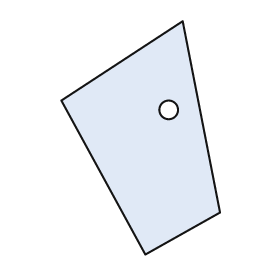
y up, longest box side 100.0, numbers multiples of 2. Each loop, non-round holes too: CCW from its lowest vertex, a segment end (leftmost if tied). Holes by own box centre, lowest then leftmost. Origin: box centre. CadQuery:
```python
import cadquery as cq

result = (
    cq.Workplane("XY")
    .moveTo(2.0, -50.0)
    .lineTo(34.0, -32.0)
    .lineTo(18.0, 50.0)
    .lineTo(-34.0, 16.0)
    .close()
    .moveTo(12.0, 12.0)
    .circle(4.0)
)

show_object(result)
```